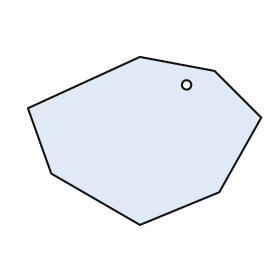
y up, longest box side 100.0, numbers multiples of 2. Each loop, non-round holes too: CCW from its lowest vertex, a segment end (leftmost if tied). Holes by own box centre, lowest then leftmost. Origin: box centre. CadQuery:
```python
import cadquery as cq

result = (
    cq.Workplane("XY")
    .moveTo(-2.0, -36.0)
    .lineTo(32.0, -22.0)
    .lineTo(50.0, 10.0)
    .lineTo(30.0, 30.0)
    .lineTo(-2.0, 36.0)
    .lineTo(-50.0, 14.0)
    .lineTo(-40.0, -14.0)
    .close()
    .moveTo(18.0, 24.0)
    .circle(2.0)
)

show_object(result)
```